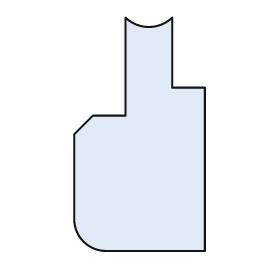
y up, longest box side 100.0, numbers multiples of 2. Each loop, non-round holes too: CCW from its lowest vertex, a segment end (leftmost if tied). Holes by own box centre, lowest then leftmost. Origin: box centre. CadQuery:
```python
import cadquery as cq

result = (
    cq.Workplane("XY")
    .moveTo(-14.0, -50.0)
    .lineTo(28.0, -50.0)
    .lineTo(28.0, 20.0)
    .lineTo(14.0, 20.0)
    .lineTo(14.0, 50.0)
    .threePointArc((4.0, 46.0), (-6.0, 50.0))
    .lineTo(-6.0, 8.0)
    .lineTo(-20.0, 8.0)
    .lineTo(-28.0, 0.0)
    .lineTo(-28.0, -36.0)
    .threePointArc((-24.0, -46.0), (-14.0, -50.0))
    .close()
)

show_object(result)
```